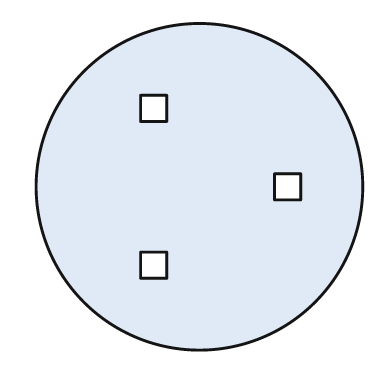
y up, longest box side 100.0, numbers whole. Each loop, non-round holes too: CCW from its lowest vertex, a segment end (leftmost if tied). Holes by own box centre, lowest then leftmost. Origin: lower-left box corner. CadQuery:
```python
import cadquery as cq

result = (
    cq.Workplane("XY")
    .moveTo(50.0, 50.0)
    .circle(50.0)
    .moveTo(32.0, 22.0)
    .lineTo(40.0, 22.0)
    .lineTo(40.0, 30.0)
    .lineTo(32.0, 30.0)
    .close()
    .moveTo(73.0, 46.0)
    .lineTo(81.0, 46.0)
    .lineTo(81.0, 54.0)
    .lineTo(73.0, 54.0)
    .close()
    .moveTo(32.0, 70.0)
    .lineTo(40.0, 70.0)
    .lineTo(40.0, 78.0)
    .lineTo(32.0, 78.0)
    .close()
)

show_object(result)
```